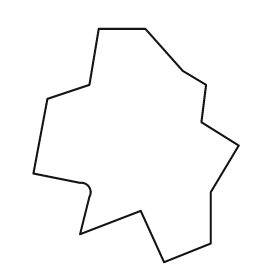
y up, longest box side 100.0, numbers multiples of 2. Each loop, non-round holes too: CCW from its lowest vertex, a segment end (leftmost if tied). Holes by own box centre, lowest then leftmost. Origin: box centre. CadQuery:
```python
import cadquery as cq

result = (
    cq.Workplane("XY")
    .moveTo(12.0, -50.0)
    .lineTo(32.0, -42.0)
    .lineTo(32.0, -20.0)
    .lineTo(44.0, 0.0)
    .lineTo(28.0, 10.0)
    .lineTo(30.0, 26.0)
    .lineTo(20.0, 32.0)
    .lineTo(4.0, 50.0)
    .lineTo(-16.0, 50.0)
    .lineTo(-20.0, 26.0)
    .lineTo(-38.0, 20.0)
    .lineTo(-44.0, -12.0)
    .lineTo(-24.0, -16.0)
    .threePointArc((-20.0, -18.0), (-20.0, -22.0))
    .lineTo(-24.0, -38.0)
    .lineTo(2.0, -28.0)
    .close()
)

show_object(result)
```